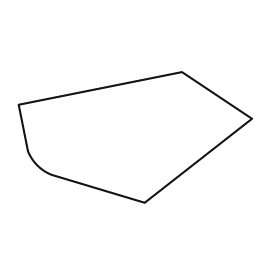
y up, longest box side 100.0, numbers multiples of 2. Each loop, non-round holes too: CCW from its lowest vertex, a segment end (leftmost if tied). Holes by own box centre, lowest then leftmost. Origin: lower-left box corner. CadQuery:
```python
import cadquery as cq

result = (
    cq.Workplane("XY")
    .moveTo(54.0, 0.0)
    .lineTo(100.0, 36.0)
    .lineTo(70.0, 56.0)
    .lineTo(0.0, 42.0)
    .lineTo(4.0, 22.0)
    .threePointArc((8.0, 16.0), (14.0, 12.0))
    .close()
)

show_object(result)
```